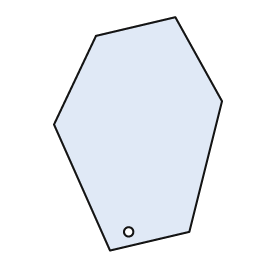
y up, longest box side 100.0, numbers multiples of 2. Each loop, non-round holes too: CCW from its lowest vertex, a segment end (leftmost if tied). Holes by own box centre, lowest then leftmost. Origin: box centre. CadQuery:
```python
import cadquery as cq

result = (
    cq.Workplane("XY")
    .moveTo(-12.0, -50.0)
    .lineTo(22.0, -42.0)
    .lineTo(36.0, 14.0)
    .lineTo(16.0, 50.0)
    .lineTo(-18.0, 42.0)
    .lineTo(-36.0, 4.0)
    .close()
    .moveTo(-4.0, -42.0)
    .circle(2.0)
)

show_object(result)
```